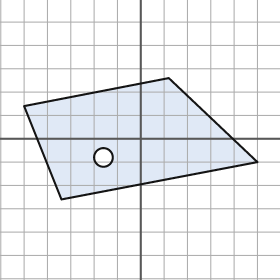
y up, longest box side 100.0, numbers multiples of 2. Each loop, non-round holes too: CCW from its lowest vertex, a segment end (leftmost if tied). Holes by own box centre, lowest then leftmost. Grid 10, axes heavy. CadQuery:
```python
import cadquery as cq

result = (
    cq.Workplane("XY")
    .moveTo(-34.0, -26.0)
    .lineTo(50.0, -10.0)
    .lineTo(12.0, 26.0)
    .lineTo(-50.0, 14.0)
    .close()
    .moveTo(-16.0, -8.0)
    .circle(4.0)
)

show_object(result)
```